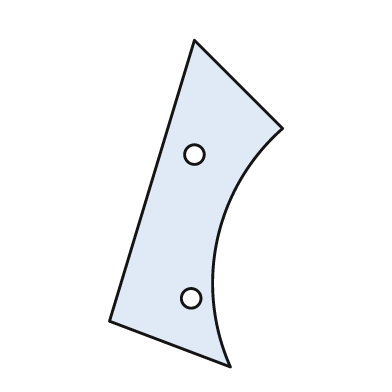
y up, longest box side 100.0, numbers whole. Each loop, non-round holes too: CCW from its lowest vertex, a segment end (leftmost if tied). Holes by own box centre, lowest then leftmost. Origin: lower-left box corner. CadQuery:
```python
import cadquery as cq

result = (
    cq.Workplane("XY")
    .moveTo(37.0, 0.0)
    .threePointArc((33.0, 39.0), (53.0, 73.0))
    .lineTo(26.0, 100.0)
    .lineTo(0.0, 14.0)
    .close()
    .moveTo(25.0, 21.0)
    .circle(3.0)
    .moveTo(26.0, 65.0)
    .circle(3.0)
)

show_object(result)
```